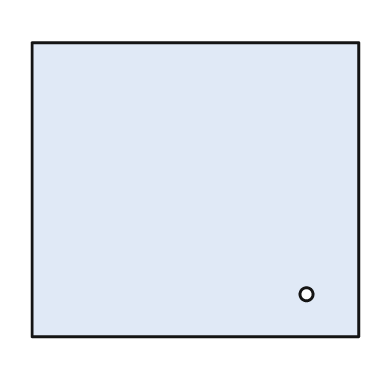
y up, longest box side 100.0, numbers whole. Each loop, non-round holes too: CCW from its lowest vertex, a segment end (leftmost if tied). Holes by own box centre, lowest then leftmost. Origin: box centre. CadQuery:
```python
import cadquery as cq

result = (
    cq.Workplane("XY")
    .moveTo(-50.0, -45.0)
    .lineTo(50.0, -45.0)
    .lineTo(50.0, 45.0)
    .lineTo(-50.0, 45.0)
    .close()
    .moveTo(34.0, -32.0)
    .circle(2.0)
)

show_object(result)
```